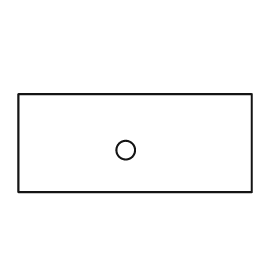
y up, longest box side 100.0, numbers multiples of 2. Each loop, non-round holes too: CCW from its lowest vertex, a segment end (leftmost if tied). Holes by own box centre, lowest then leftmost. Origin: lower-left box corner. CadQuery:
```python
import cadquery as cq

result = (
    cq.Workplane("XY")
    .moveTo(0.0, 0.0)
    .lineTo(100.0, 0.0)
    .lineTo(100.0, 42.0)
    .lineTo(0.0, 42.0)
    .close()
    .moveTo(46.0, 18.0)
    .circle(4.0)
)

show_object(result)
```